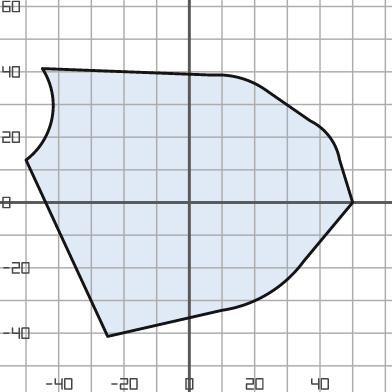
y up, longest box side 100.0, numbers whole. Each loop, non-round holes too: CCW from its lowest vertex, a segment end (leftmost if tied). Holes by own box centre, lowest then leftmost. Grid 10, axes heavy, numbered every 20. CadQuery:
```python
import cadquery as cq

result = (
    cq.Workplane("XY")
    .moveTo(-25.0, -41.0)
    .lineTo(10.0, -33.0)
    .threePointArc((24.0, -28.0), (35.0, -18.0))
    .lineTo(50.0, 0.0)
    .lineTo(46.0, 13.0)
    .threePointArc((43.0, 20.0), (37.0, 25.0))
    .lineTo(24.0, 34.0)
    .threePointArc((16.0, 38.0), (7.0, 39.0))
    .lineTo(-45.0, 41.0)
    .threePointArc((-42.0, 26.0), (-50.0, 13.0))
    .close()
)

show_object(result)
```